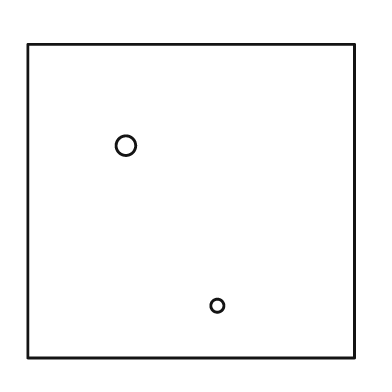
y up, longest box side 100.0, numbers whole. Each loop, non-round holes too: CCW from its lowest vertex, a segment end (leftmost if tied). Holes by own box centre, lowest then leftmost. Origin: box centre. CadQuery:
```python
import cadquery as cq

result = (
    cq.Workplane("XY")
    .moveTo(-50.0, -48.0)
    .lineTo(50.0, -48.0)
    .lineTo(50.0, 48.0)
    .lineTo(-50.0, 48.0)
    .close()
    .moveTo(8.0, -32.0)
    .circle(2.0)
    .moveTo(-20.0, 17.0)
    .circle(3.0)
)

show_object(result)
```